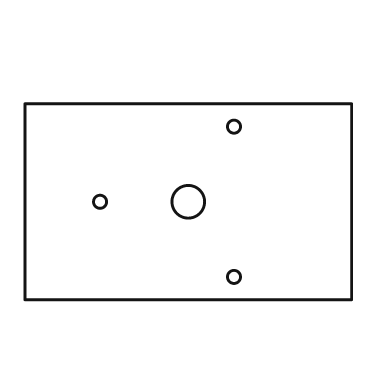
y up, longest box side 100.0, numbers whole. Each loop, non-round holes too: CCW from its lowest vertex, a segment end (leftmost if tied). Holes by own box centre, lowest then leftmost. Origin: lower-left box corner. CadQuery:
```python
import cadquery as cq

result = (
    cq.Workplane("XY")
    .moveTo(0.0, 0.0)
    .lineTo(100.0, 0.0)
    .lineTo(100.0, 60.0)
    .lineTo(0.0, 60.0)
    .close()
    .moveTo(64.0, 7.0)
    .circle(2.0)
    .moveTo(23.0, 30.0)
    .circle(2.0)
    .moveTo(50.0, 30.0)
    .circle(5.0)
    .moveTo(64.0, 53.0)
    .circle(2.0)
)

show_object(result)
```